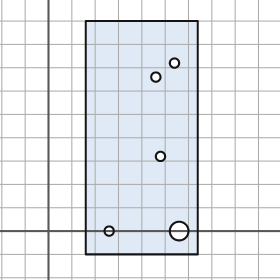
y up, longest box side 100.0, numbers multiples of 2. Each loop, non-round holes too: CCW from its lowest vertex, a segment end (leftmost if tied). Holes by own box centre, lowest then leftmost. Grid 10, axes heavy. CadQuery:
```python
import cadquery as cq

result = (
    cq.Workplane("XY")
    .moveTo(16.0, -10.0)
    .lineTo(64.0, -10.0)
    .lineTo(64.0, 90.0)
    .lineTo(16.0, 90.0)
    .close()
    .moveTo(26.0, 0.0)
    .circle(2.0)
    .moveTo(56.0, 0.0)
    .circle(4.0)
    .moveTo(48.0, 32.0)
    .circle(2.0)
    .moveTo(46.0, 66.0)
    .circle(2.0)
    .moveTo(54.0, 72.0)
    .circle(2.0)
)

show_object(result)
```